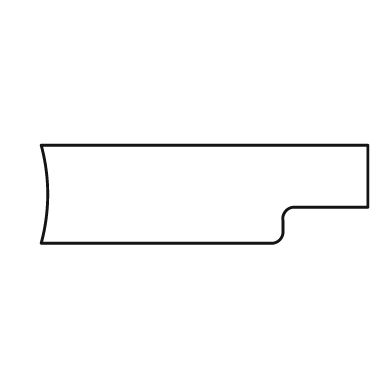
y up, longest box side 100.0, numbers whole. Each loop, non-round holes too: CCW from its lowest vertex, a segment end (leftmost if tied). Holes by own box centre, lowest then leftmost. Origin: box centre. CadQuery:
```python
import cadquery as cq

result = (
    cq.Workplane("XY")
    .moveTo(-50.0, -15.0)
    .lineTo(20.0, -15.0)
    .threePointArc((23.0, -14.0), (24.0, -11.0))
    .lineTo(24.0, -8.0)
    .threePointArc((25.0, -5.0), (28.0, -4.0))
    .lineTo(50.0, -4.0)
    .lineTo(50.0, 15.0)
    .lineTo(-50.0, 15.0)
    .threePointArc((-48.0, 0.0), (-50.0, -15.0))
    .close()
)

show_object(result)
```